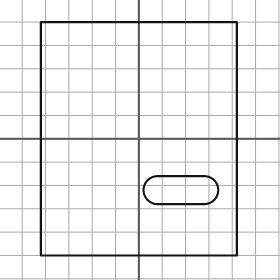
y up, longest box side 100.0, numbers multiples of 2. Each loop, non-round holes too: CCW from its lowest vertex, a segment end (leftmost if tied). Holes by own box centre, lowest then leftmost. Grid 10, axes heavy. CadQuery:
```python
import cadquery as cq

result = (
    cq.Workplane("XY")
    .moveTo(-42.0, -50.0)
    .lineTo(42.0, -50.0)
    .lineTo(42.0, 50.0)
    .lineTo(-42.0, 50.0)
    .close()
    .moveTo(8.0, -28.0)
    .lineTo(28.0, -28.0)
    .threePointArc((34.0, -22.0), (28.0, -16.0))
    .lineTo(8.0, -16.0)
    .threePointArc((2.0, -22.0), (8.0, -28.0))
    .close()
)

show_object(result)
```